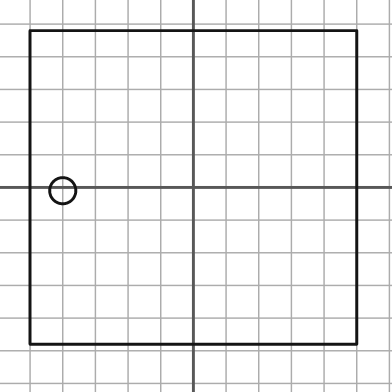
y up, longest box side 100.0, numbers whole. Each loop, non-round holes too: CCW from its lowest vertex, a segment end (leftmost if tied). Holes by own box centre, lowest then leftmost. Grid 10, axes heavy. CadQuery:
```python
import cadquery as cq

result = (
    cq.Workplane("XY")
    .moveTo(-50.0, -48.0)
    .lineTo(50.0, -48.0)
    .lineTo(50.0, 48.0)
    .lineTo(-50.0, 48.0)
    .close()
    .moveTo(-40.0, -1.0)
    .circle(4.0)
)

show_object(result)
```